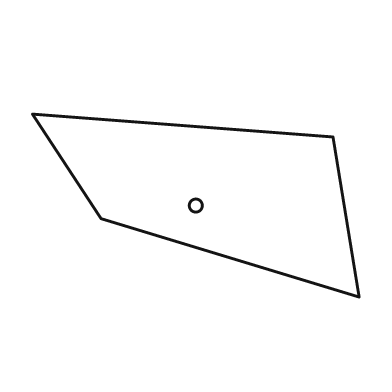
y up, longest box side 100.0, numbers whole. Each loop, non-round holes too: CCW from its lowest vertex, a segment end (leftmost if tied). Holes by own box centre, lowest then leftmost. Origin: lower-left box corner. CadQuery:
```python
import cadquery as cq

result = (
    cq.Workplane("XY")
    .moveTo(100.0, 0.0)
    .lineTo(92.0, 49.0)
    .lineTo(0.0, 56.0)
    .lineTo(21.0, 24.0)
    .close()
    .moveTo(50.0, 28.0)
    .circle(2.0)
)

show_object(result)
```